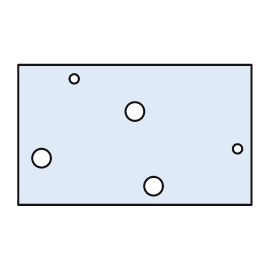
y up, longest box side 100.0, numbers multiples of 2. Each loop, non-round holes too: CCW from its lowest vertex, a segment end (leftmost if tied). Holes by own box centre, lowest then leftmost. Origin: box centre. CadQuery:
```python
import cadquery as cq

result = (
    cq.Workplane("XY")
    .moveTo(-50.0, -30.0)
    .lineTo(50.0, -30.0)
    .lineTo(50.0, 30.0)
    .lineTo(-50.0, 30.0)
    .close()
    .moveTo(8.0, -22.0)
    .circle(4.0)
    .moveTo(-40.0, -10.0)
    .circle(4.0)
    .moveTo(44.0, -6.0)
    .circle(2.0)
    .moveTo(0.0, 10.0)
    .circle(4.0)
    .moveTo(-26.0, 24.0)
    .circle(2.0)
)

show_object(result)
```